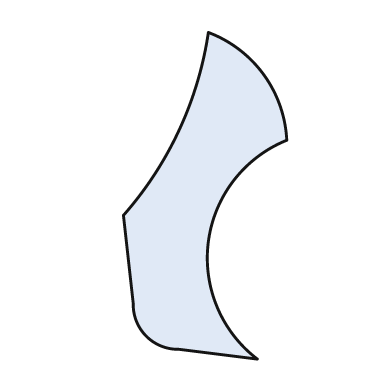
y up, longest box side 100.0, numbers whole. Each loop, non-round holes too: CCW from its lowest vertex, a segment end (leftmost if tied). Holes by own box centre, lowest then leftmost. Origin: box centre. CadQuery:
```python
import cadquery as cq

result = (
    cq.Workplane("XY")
    .moveTo(16.0, -50.0)
    .threePointArc((1.0, -14.0), (25.0, 17.0))
    .threePointArc((18.0, 37.0), (1.0, 50.0))
    .threePointArc((-8.0, 20.0), (-25.0, -6.0))
    .lineTo(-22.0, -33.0)
    .threePointArc((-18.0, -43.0), (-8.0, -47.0))
    .close()
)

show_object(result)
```